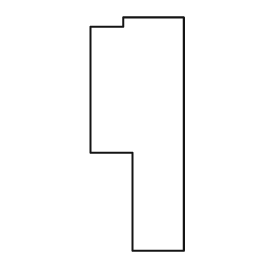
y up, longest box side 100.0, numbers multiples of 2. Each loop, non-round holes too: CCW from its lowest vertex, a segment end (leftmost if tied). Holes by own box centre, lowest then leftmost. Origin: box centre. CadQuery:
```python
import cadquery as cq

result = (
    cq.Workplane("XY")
    .moveTo(-2.0, -50.0)
    .lineTo(20.0, -50.0)
    .lineTo(20.0, 50.0)
    .lineTo(-6.0, 50.0)
    .lineTo(-6.0, 46.0)
    .lineTo(-20.0, 46.0)
    .lineTo(-20.0, -8.0)
    .lineTo(-2.0, -8.0)
    .close()
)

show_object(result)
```